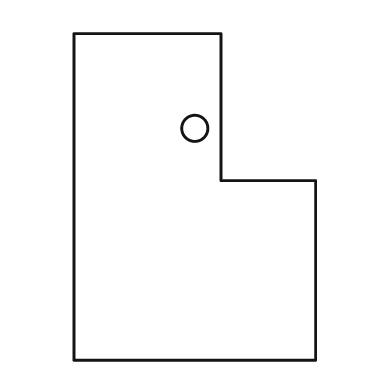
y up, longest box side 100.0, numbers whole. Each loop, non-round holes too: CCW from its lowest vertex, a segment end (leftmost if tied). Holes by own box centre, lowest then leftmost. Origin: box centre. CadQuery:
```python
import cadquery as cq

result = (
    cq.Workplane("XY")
    .moveTo(-37.0, -50.0)
    .lineTo(37.0, -50.0)
    .lineTo(37.0, 5.0)
    .lineTo(8.0, 5.0)
    .lineTo(8.0, 50.0)
    .lineTo(-37.0, 50.0)
    .close()
    .moveTo(0.0, 21.0)
    .circle(4.0)
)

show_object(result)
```